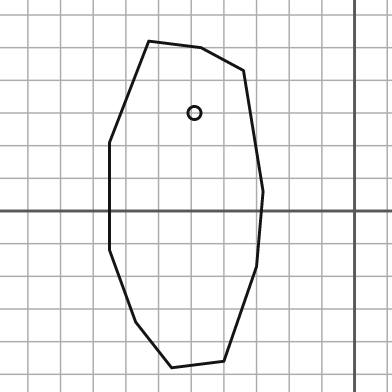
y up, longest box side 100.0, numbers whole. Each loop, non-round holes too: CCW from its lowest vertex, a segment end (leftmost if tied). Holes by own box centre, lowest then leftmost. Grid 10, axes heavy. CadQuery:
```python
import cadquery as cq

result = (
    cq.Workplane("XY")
    .moveTo(-56.0, -48.0)
    .lineTo(-40.0, -46.0)
    .lineTo(-30.0, -17.0)
    .lineTo(-28.0, 6.0)
    .lineTo(-34.0, 43.0)
    .lineTo(-47.0, 50.0)
    .lineTo(-63.0, 52.0)
    .lineTo(-75.0, 21.0)
    .lineTo(-75.0, -12.0)
    .lineTo(-67.0, -34.0)
    .close()
    .moveTo(-49.0, 30.0)
    .circle(2.0)
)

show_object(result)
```